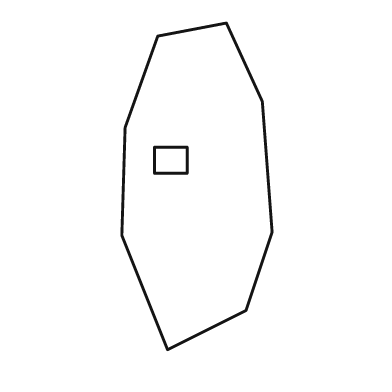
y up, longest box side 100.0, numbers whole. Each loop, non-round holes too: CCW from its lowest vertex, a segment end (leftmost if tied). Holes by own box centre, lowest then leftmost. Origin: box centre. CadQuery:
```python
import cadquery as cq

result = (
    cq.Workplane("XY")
    .moveTo(-9.0, -50.0)
    .lineTo(15.0, -38.0)
    .lineTo(23.0, -14.0)
    .lineTo(20.0, 26.0)
    .lineTo(9.0, 50.0)
    .lineTo(-12.0, 46.0)
    .lineTo(-22.0, 18.0)
    .lineTo(-23.0, -15.0)
    .close()
    .moveTo(-13.0, 4.0)
    .lineTo(-3.0, 4.0)
    .lineTo(-3.0, 12.0)
    .lineTo(-13.0, 12.0)
    .close()
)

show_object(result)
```